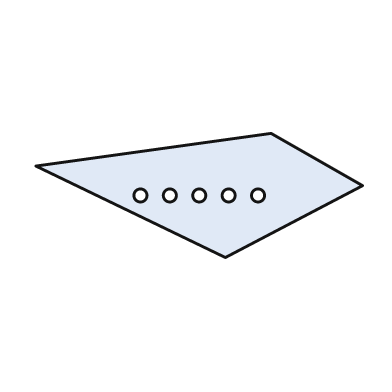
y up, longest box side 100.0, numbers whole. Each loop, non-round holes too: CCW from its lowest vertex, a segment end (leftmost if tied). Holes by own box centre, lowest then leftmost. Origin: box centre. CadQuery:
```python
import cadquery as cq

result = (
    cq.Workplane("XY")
    .moveTo(8.0, -19.0)
    .lineTo(50.0, 3.0)
    .lineTo(22.0, 19.0)
    .lineTo(-50.0, 9.0)
    .close()
    .moveTo(-18.0, 0.0)
    .circle(2.0)
    .moveTo(-9.0, 0.0)
    .circle(2.0)
    .moveTo(0.0, 0.0)
    .circle(2.0)
    .moveTo(9.0, 0.0)
    .circle(2.0)
    .moveTo(18.0, 0.0)
    .circle(2.0)
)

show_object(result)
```